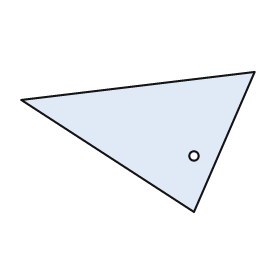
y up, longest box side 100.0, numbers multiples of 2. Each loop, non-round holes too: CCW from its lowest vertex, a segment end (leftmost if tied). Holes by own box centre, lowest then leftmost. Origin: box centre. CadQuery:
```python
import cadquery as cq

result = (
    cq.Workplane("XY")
    .moveTo(24.0, -30.0)
    .lineTo(50.0, 30.0)
    .lineTo(-50.0, 18.0)
    .close()
    .moveTo(24.0, -6.0)
    .circle(2.0)
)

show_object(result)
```